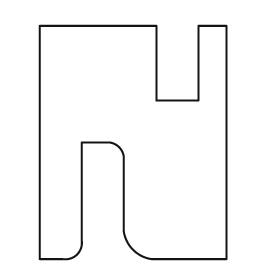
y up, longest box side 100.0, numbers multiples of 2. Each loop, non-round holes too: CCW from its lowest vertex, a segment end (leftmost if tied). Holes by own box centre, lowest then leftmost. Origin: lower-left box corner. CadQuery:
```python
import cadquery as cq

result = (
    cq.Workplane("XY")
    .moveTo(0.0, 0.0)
    .lineTo(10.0, 0.0)
    .threePointArc((16.0, 2.0), (18.0, 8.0))
    .lineTo(18.0, 50.0)
    .lineTo(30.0, 50.0)
    .threePointArc((34.0, 48.0), (36.0, 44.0))
    .lineTo(36.0, 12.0)
    .threePointArc((40.0, 4.0), (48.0, 0.0))
    .lineTo(80.0, 0.0)
    .lineTo(80.0, 100.0)
    .lineTo(68.0, 100.0)
    .lineTo(68.0, 68.0)
    .lineTo(50.0, 68.0)
    .lineTo(50.0, 100.0)
    .lineTo(0.0, 100.0)
    .close()
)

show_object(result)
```